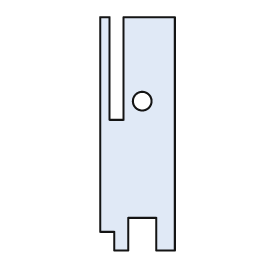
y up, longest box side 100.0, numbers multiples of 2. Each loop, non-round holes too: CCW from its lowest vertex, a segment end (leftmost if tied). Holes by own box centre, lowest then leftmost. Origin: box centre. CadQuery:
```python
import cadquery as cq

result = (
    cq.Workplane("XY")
    .moveTo(-10.0, -50.0)
    .lineTo(-4.0, -50.0)
    .lineTo(-4.0, -36.0)
    .lineTo(8.0, -36.0)
    .lineTo(8.0, -50.0)
    .lineTo(16.0, -50.0)
    .lineTo(16.0, 50.0)
    .lineTo(-6.0, 50.0)
    .lineTo(-6.0, 6.0)
    .lineTo(-12.0, 6.0)
    .lineTo(-12.0, 50.0)
    .lineTo(-16.0, 50.0)
    .lineTo(-16.0, -42.0)
    .lineTo(-10.0, -42.0)
    .close()
    .moveTo(2.0, 14.0)
    .circle(4.0)
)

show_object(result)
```